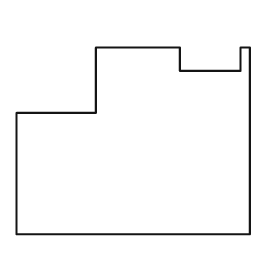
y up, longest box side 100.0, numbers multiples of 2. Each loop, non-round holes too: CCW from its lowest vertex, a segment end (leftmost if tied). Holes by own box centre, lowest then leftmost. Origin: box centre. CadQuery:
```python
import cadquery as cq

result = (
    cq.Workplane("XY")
    .moveTo(-50.0, -40.0)
    .lineTo(50.0, -40.0)
    .lineTo(50.0, 40.0)
    .lineTo(46.0, 40.0)
    .lineTo(46.0, 30.0)
    .lineTo(20.0, 30.0)
    .lineTo(20.0, 40.0)
    .lineTo(-16.0, 40.0)
    .lineTo(-16.0, 12.0)
    .lineTo(-50.0, 12.0)
    .close()
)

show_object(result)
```